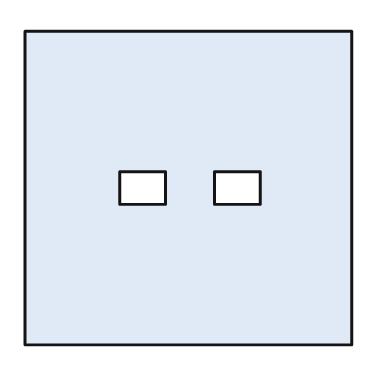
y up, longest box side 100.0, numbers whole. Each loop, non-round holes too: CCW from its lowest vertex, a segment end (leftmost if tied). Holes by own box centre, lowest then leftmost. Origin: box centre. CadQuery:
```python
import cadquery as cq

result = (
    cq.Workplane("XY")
    .moveTo(-50.0, -48.0)
    .lineTo(50.0, -48.0)
    .lineTo(50.0, 48.0)
    .lineTo(-50.0, 48.0)
    .close()
    .moveTo(-21.0, -5.0)
    .lineTo(-7.0, -5.0)
    .lineTo(-7.0, 5.0)
    .lineTo(-21.0, 5.0)
    .close()
    .moveTo(8.0, -5.0)
    .lineTo(22.0, -5.0)
    .lineTo(22.0, 5.0)
    .lineTo(8.0, 5.0)
    .close()
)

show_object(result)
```